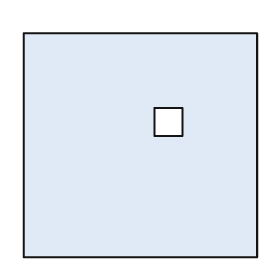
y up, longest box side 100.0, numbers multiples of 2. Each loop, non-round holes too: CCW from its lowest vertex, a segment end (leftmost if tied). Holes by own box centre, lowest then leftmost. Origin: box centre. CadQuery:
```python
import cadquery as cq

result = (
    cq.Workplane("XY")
    .moveTo(-50.0, -48.0)
    .lineTo(50.0, -48.0)
    .lineTo(50.0, 48.0)
    .lineTo(-50.0, 48.0)
    .close()
    .moveTo(6.0, 4.0)
    .lineTo(18.0, 4.0)
    .lineTo(18.0, 16.0)
    .lineTo(6.0, 16.0)
    .close()
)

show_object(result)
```